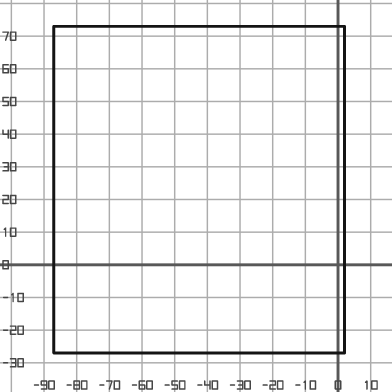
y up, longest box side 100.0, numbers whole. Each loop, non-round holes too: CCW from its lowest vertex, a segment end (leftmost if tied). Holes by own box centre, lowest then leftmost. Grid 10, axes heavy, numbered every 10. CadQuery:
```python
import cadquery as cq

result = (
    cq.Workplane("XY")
    .moveTo(-87.0, -27.0)
    .lineTo(2.0, -27.0)
    .lineTo(2.0, 73.0)
    .lineTo(-87.0, 73.0)
    .close()
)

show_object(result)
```